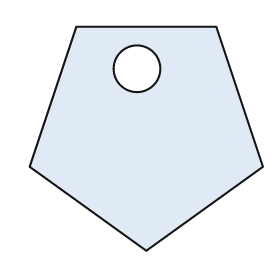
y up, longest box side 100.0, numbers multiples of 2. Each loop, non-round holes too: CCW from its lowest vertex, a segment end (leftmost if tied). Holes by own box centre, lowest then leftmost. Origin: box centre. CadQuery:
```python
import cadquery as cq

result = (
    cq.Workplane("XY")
    .moveTo(0.0, -48.0)
    .lineTo(50.0, -12.0)
    .lineTo(30.0, 48.0)
    .lineTo(-30.0, 48.0)
    .lineTo(-50.0, -12.0)
    .close()
    .moveTo(-4.0, 30.0)
    .circle(10.0)
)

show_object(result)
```